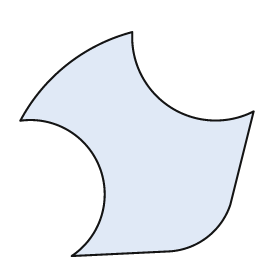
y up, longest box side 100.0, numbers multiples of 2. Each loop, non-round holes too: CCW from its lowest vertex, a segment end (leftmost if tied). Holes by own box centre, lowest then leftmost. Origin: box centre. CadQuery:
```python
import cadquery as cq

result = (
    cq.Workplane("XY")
    .moveTo(-28.0, -48.0)
    .lineTo(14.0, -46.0)
    .threePointArc((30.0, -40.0), (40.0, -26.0))
    .lineTo(50.0, 14.0)
    .threePointArc((14.0, 16.0), (-2.0, 48.0))
    .threePointArc((-30.0, 34.0), (-50.0, 10.0))
    .threePointArc((-16.0, -10.0), (-28.0, -48.0))
    .close()
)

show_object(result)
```